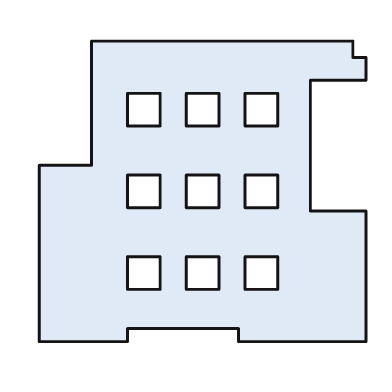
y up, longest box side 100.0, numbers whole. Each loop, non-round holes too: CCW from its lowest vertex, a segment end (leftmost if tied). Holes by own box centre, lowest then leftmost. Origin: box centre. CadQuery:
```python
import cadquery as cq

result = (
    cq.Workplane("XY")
    .moveTo(-50.0, -46.0)
    .lineTo(-23.0, -46.0)
    .lineTo(-23.0, -42.0)
    .lineTo(11.0, -42.0)
    .lineTo(11.0, -46.0)
    .lineTo(50.0, -46.0)
    .lineTo(50.0, -6.0)
    .lineTo(33.0, -6.0)
    .lineTo(33.0, 34.0)
    .lineTo(50.0, 34.0)
    .lineTo(50.0, 41.0)
    .lineTo(46.0, 41.0)
    .lineTo(46.0, 46.0)
    .lineTo(-34.0, 46.0)
    .lineTo(-34.0, 8.0)
    .lineTo(-50.0, 8.0)
    .close()
    .moveTo(-23.0, -30.0)
    .lineTo(-13.0, -30.0)
    .lineTo(-13.0, -20.0)
    .lineTo(-23.0, -20.0)
    .close()
    .moveTo(-5.0, -30.0)
    .lineTo(5.0, -30.0)
    .lineTo(5.0, -20.0)
    .lineTo(-5.0, -20.0)
    .close()
    .moveTo(13.0, -30.0)
    .lineTo(23.0, -30.0)
    .lineTo(23.0, -20.0)
    .lineTo(13.0, -20.0)
    .close()
    .moveTo(-23.0, -5.0)
    .lineTo(-13.0, -5.0)
    .lineTo(-13.0, 5.0)
    .lineTo(-23.0, 5.0)
    .close()
    .moveTo(-5.0, -5.0)
    .lineTo(5.0, -5.0)
    .lineTo(5.0, 5.0)
    .lineTo(-5.0, 5.0)
    .close()
    .moveTo(13.0, -5.0)
    .lineTo(23.0, -5.0)
    .lineTo(23.0, 5.0)
    .lineTo(13.0, 5.0)
    .close()
    .moveTo(-23.0, 20.0)
    .lineTo(-13.0, 20.0)
    .lineTo(-13.0, 30.0)
    .lineTo(-23.0, 30.0)
    .close()
    .moveTo(-5.0, 20.0)
    .lineTo(5.0, 20.0)
    .lineTo(5.0, 30.0)
    .lineTo(-5.0, 30.0)
    .close()
    .moveTo(13.0, 20.0)
    .lineTo(23.0, 20.0)
    .lineTo(23.0, 30.0)
    .lineTo(13.0, 30.0)
    .close()
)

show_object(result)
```